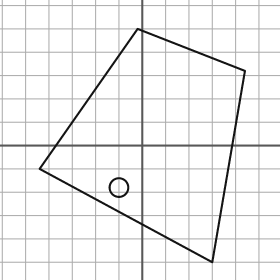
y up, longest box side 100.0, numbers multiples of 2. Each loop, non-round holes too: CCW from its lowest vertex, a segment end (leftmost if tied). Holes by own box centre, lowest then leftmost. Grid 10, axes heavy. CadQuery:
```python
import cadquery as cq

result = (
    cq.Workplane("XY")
    .moveTo(30.0, -50.0)
    .lineTo(44.0, 32.0)
    .lineTo(-2.0, 50.0)
    .lineTo(-44.0, -10.0)
    .close()
    .moveTo(-10.0, -18.0)
    .circle(4.0)
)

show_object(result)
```